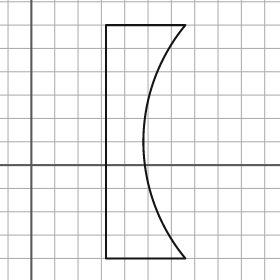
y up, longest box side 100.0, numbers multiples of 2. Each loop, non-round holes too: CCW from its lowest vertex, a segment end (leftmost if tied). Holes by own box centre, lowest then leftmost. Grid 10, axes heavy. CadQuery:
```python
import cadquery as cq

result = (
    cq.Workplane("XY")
    .moveTo(32.0, -40.0)
    .lineTo(66.0, -40.0)
    .threePointArc((48.0, 10.0), (66.0, 60.0))
    .lineTo(32.0, 60.0)
    .close()
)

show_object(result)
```